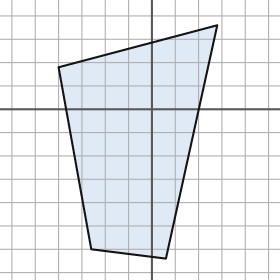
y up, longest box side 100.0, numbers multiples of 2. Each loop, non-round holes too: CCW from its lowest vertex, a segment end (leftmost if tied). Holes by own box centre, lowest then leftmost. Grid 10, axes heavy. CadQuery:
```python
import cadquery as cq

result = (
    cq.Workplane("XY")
    .moveTo(6.0, -64.0)
    .lineTo(28.0, 36.0)
    .lineTo(-40.0, 18.0)
    .lineTo(-26.0, -60.0)
    .close()
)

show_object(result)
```